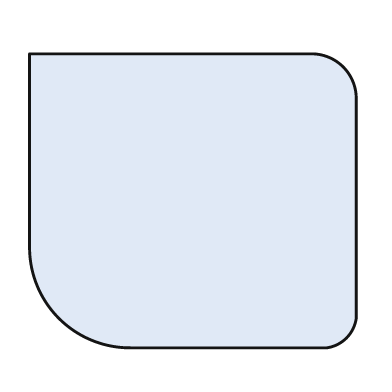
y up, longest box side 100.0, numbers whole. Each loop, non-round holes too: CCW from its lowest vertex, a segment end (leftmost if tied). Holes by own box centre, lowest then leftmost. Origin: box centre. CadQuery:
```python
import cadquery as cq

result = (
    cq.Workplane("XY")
    .moveTo(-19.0, -45.0)
    .lineTo(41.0, -45.0)
    .threePointArc((47.0, -42.0), (50.0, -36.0))
    .lineTo(50.0, 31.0)
    .threePointArc((46.0, 41.0), (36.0, 45.0))
    .lineTo(-50.0, 45.0)
    .lineTo(-50.0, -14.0)
    .threePointArc((-41.0, -36.0), (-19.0, -45.0))
    .close()
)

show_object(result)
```